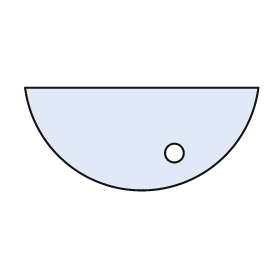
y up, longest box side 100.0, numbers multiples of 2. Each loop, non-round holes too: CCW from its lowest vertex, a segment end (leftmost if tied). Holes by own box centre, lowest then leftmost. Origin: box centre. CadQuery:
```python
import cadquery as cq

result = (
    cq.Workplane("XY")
    .moveTo(-50.0, 22.0)
    .threePointArc((0.0, -22.0), (50.0, 22.0))
    .close()
    .moveTo(14.0, -6.0)
    .circle(4.0)
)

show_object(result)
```